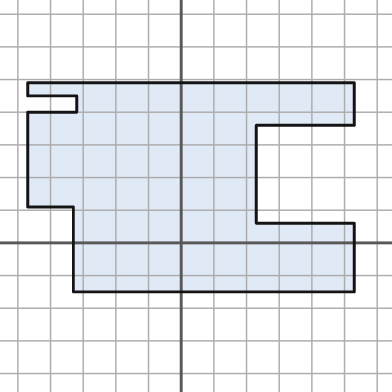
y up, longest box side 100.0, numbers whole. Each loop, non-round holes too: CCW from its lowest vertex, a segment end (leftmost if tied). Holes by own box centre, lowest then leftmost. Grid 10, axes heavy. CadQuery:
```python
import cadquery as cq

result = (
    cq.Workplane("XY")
    .moveTo(-33.0, -15.0)
    .lineTo(53.0, -15.0)
    .lineTo(53.0, 6.0)
    .lineTo(23.0, 6.0)
    .lineTo(23.0, 36.0)
    .lineTo(53.0, 36.0)
    .lineTo(53.0, 49.0)
    .lineTo(-47.0, 49.0)
    .lineTo(-47.0, 45.0)
    .lineTo(-32.0, 45.0)
    .lineTo(-32.0, 40.0)
    .lineTo(-47.0, 40.0)
    .lineTo(-47.0, 11.0)
    .lineTo(-33.0, 11.0)
    .close()
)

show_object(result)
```